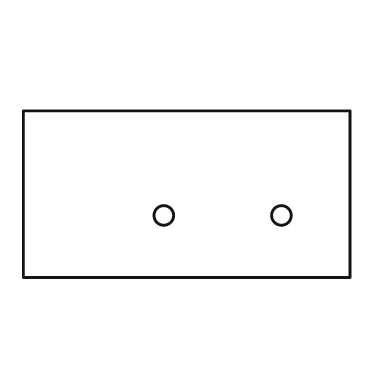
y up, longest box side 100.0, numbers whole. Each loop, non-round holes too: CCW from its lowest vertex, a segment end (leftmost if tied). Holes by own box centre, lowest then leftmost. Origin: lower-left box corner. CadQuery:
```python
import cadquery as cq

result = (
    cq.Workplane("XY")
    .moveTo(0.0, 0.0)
    .lineTo(100.0, 0.0)
    .lineTo(100.0, 51.0)
    .lineTo(0.0, 51.0)
    .close()
    .moveTo(43.0, 19.0)
    .circle(3.0)
    .moveTo(79.0, 19.0)
    .circle(3.0)
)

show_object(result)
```